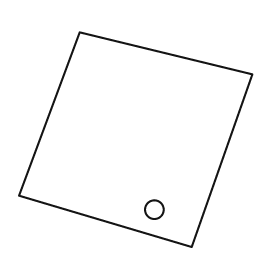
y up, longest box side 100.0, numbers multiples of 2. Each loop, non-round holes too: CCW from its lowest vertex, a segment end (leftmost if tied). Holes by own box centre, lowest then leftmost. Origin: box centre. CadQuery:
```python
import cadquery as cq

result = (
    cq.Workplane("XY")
    .moveTo(24.0, -46.0)
    .lineTo(50.0, 28.0)
    .lineTo(-24.0, 46.0)
    .lineTo(-50.0, -24.0)
    .close()
    .moveTo(8.0, -30.0)
    .circle(4.0)
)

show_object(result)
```